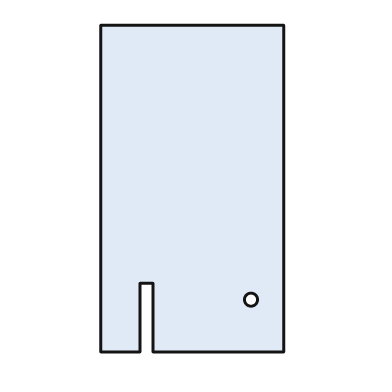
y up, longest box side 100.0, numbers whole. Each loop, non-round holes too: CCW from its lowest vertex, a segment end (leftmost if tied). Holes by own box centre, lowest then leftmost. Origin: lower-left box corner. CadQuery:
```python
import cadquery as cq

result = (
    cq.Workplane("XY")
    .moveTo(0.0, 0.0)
    .lineTo(12.0, 0.0)
    .lineTo(12.0, 21.0)
    .lineTo(16.0, 21.0)
    .lineTo(16.0, 0.0)
    .lineTo(56.0, 0.0)
    .lineTo(56.0, 100.0)
    .lineTo(0.0, 100.0)
    .close()
    .moveTo(46.0, 16.0)
    .circle(2.0)
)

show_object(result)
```